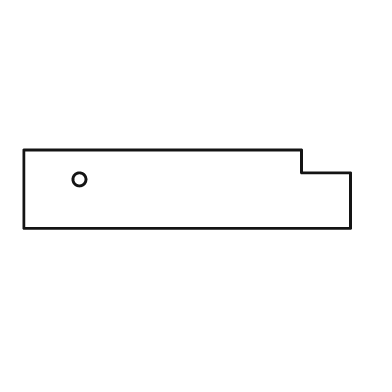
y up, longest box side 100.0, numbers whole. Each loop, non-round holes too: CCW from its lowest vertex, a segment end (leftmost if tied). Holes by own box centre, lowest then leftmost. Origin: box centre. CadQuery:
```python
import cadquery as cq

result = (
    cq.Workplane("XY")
    .moveTo(-50.0, -12.0)
    .lineTo(50.0, -12.0)
    .lineTo(50.0, 5.0)
    .lineTo(35.0, 5.0)
    .lineTo(35.0, 12.0)
    .lineTo(-50.0, 12.0)
    .close()
    .moveTo(-33.0, 3.0)
    .circle(2.0)
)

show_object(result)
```